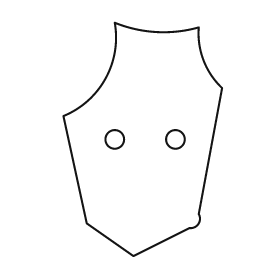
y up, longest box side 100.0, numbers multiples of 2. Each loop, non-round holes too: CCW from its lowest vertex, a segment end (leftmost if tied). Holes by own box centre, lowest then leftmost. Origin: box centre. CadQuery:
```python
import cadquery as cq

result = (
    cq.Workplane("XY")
    .moveTo(-4.0, -50.0)
    .lineTo(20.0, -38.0)
    .threePointArc((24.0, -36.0), (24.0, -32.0))
    .lineTo(34.0, 22.0)
    .threePointArc((26.0, 34.0), (24.0, 48.0))
    .threePointArc((6.0, 46.0), (-12.0, 50.0))
    .threePointArc((-16.0, 26.0), (-34.0, 10.0))
    .lineTo(-24.0, -36.0)
    .close()
    .moveTo(-12.0, 0.0)
    .circle(4.0)
    .moveTo(14.0, 0.0)
    .circle(4.0)
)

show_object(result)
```